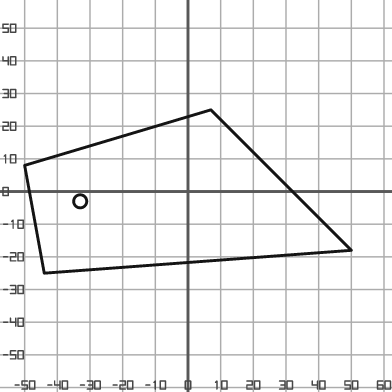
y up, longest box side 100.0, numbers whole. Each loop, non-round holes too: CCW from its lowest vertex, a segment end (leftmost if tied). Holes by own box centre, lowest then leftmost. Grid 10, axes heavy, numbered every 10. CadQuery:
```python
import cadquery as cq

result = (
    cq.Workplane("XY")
    .moveTo(-44.0, -25.0)
    .lineTo(50.0, -18.0)
    .lineTo(7.0, 25.0)
    .lineTo(-50.0, 8.0)
    .close()
    .moveTo(-33.0, -3.0)
    .circle(2.0)
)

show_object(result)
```